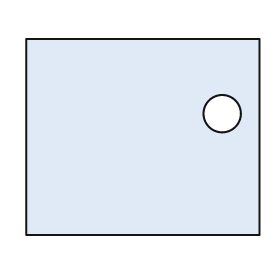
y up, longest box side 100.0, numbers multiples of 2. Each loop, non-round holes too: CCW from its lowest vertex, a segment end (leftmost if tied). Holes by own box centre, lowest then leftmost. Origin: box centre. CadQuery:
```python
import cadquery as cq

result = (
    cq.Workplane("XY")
    .moveTo(-50.0, -42.0)
    .lineTo(50.0, -42.0)
    .lineTo(50.0, 42.0)
    .lineTo(-50.0, 42.0)
    .close()
    .moveTo(34.0, 10.0)
    .circle(8.0)
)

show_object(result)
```